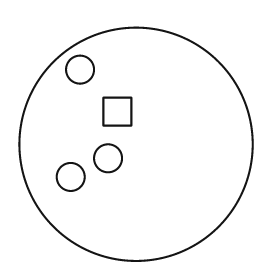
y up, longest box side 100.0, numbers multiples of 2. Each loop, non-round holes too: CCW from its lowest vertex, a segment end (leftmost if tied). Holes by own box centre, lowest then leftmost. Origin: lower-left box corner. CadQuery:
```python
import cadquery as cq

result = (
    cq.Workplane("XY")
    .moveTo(50.0, 50.0)
    .circle(50.0)
    .moveTo(22.0, 36.0)
    .circle(6.0)
    .moveTo(38.0, 44.0)
    .circle(6.0)
    .moveTo(36.0, 58.0)
    .lineTo(48.0, 58.0)
    .lineTo(48.0, 70.0)
    .lineTo(36.0, 70.0)
    .close()
    .moveTo(26.0, 82.0)
    .circle(6.0)
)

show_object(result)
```